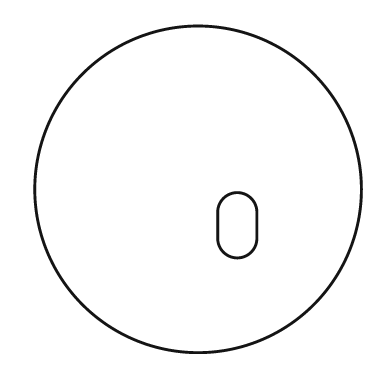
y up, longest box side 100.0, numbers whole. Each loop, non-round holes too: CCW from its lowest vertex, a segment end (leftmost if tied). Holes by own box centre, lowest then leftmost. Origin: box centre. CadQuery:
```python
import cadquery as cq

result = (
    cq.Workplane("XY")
    .moveTo(0.0, 0.0)
    .circle(50.0)
    .moveTo(6.0, -15.0)
    .threePointArc((12.0, -21.0), (18.0, -15.0))
    .lineTo(18.0, -7.0)
    .threePointArc((12.0, -1.0), (6.0, -7.0))
    .close()
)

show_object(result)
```